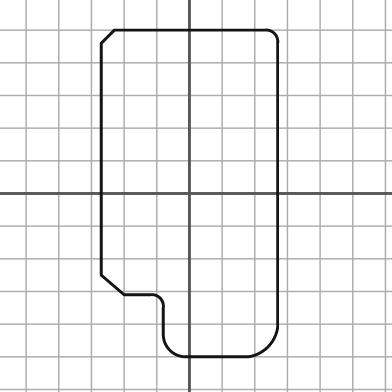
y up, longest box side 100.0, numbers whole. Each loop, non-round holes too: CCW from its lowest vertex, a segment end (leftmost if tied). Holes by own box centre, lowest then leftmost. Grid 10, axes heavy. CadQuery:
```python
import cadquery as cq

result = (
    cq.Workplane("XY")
    .moveTo(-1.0, -50.0)
    .lineTo(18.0, -50.0)
    .threePointArc((24.0, -47.0), (27.0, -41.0))
    .lineTo(27.0, 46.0)
    .threePointArc((26.0, 49.0), (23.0, 50.0))
    .lineTo(-23.0, 50.0)
    .lineTo(-27.0, 46.0)
    .lineTo(-27.0, -25.0)
    .lineTo(-20.0, -31.0)
    .lineTo(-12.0, -31.0)
    .threePointArc((-9.0, -32.0), (-8.0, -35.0))
    .lineTo(-8.0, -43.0)
    .threePointArc((-6.0, -48.0), (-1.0, -50.0))
    .close()
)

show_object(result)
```